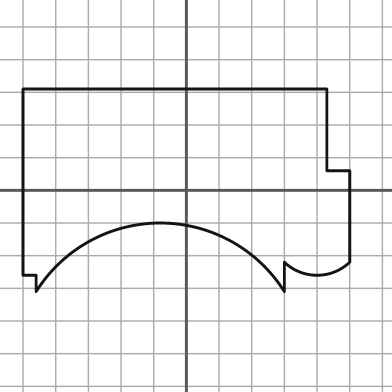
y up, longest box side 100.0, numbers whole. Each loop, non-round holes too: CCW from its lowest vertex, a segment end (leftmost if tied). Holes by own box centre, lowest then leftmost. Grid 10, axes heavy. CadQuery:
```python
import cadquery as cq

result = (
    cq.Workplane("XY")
    .moveTo(-46.0, -31.0)
    .threePointArc((-8.0, -10.0), (30.0, -31.0))
    .lineTo(30.0, -22.0)
    .threePointArc((40.0, -26.0), (50.0, -22.0))
    .lineTo(50.0, 6.0)
    .lineTo(43.0, 6.0)
    .lineTo(43.0, 31.0)
    .lineTo(-50.0, 31.0)
    .lineTo(-50.0, -26.0)
    .lineTo(-46.0, -26.0)
    .close()
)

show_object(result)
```